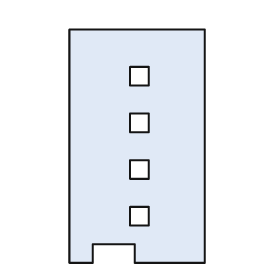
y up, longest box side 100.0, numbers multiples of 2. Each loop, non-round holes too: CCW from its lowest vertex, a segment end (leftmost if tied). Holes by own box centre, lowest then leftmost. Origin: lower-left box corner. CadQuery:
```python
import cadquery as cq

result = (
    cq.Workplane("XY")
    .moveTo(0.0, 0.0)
    .lineTo(10.0, 0.0)
    .lineTo(10.0, 8.0)
    .lineTo(28.0, 8.0)
    .lineTo(28.0, 0.0)
    .lineTo(58.0, 0.0)
    .lineTo(58.0, 100.0)
    .lineTo(0.0, 100.0)
    .close()
    .moveTo(26.0, 16.0)
    .lineTo(34.0, 16.0)
    .lineTo(34.0, 24.0)
    .lineTo(26.0, 24.0)
    .close()
    .moveTo(26.0, 36.0)
    .lineTo(34.0, 36.0)
    .lineTo(34.0, 44.0)
    .lineTo(26.0, 44.0)
    .close()
    .moveTo(26.0, 56.0)
    .lineTo(34.0, 56.0)
    .lineTo(34.0, 64.0)
    .lineTo(26.0, 64.0)
    .close()
    .moveTo(26.0, 76.0)
    .lineTo(34.0, 76.0)
    .lineTo(34.0, 84.0)
    .lineTo(26.0, 84.0)
    .close()
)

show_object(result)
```